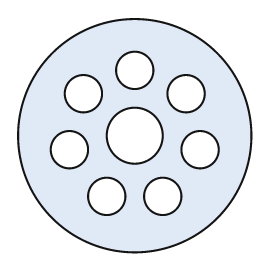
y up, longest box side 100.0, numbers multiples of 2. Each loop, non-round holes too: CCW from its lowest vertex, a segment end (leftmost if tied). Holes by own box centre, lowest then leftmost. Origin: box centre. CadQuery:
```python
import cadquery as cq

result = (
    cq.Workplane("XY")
    .moveTo(0.0, 0.0)
    .circle(50.0)
    .moveTo(-12.0, -26.0)
    .circle(8.0)
    .moveTo(12.0, -26.0)
    .circle(8.0)
    .moveTo(-28.0, -6.0)
    .circle(8.0)
    .moveTo(28.0, -6.0)
    .circle(8.0)
    .moveTo(0.0, 0.0)
    .circle(12.0)
    .moveTo(-22.0, 18.0)
    .circle(8.0)
    .moveTo(22.0, 18.0)
    .circle(8.0)
    .moveTo(0.0, 28.0)
    .circle(8.0)
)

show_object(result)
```